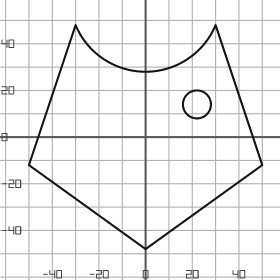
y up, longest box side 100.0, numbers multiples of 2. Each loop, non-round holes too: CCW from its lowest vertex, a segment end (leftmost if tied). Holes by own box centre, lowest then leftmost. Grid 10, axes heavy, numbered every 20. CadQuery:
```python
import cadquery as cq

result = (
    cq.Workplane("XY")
    .moveTo(0.0, -48.0)
    .lineTo(50.0, -12.0)
    .lineTo(30.0, 48.0)
    .threePointArc((0.0, 28.0), (-30.0, 48.0))
    .lineTo(-50.0, -12.0)
    .close()
    .moveTo(22.0, 14.0)
    .circle(6.0)
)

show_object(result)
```